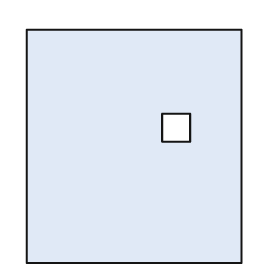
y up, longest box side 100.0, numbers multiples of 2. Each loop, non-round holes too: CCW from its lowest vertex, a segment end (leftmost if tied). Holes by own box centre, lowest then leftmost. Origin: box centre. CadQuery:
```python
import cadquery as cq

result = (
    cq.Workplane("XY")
    .moveTo(-46.0, -50.0)
    .lineTo(46.0, -50.0)
    .lineTo(46.0, 50.0)
    .lineTo(-46.0, 50.0)
    .close()
    .moveTo(12.0, 2.0)
    .lineTo(24.0, 2.0)
    .lineTo(24.0, 14.0)
    .lineTo(12.0, 14.0)
    .close()
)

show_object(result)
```